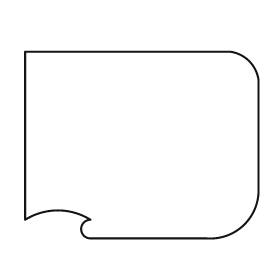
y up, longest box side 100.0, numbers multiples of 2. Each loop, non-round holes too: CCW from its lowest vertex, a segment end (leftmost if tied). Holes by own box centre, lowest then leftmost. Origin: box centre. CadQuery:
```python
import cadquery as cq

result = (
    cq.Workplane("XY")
    .moveTo(-22.0, -40.0)
    .lineTo(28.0, -40.0)
    .threePointArc((44.0, -34.0), (50.0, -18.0))
    .lineTo(50.0, 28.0)
    .threePointArc((46.0, 36.0), (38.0, 40.0))
    .lineTo(-50.0, 40.0)
    .lineTo(-50.0, -32.0)
    .threePointArc((-36.0, -28.0), (-22.0, -32.0))
    .threePointArc((-26.0, -36.0), (-22.0, -40.0))
    .close()
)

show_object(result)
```